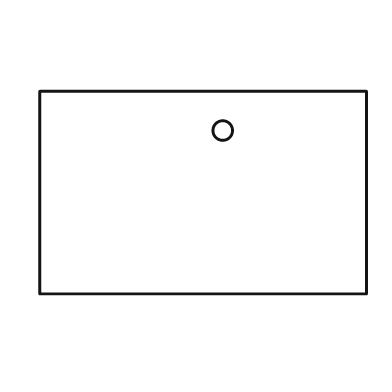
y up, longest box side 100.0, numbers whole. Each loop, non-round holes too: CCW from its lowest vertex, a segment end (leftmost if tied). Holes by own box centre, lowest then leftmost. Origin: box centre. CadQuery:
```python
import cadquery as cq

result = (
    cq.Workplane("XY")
    .moveTo(-50.0, -31.0)
    .lineTo(50.0, -31.0)
    .lineTo(50.0, 31.0)
    .lineTo(-50.0, 31.0)
    .close()
    .moveTo(6.0, 19.0)
    .circle(3.0)
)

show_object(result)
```